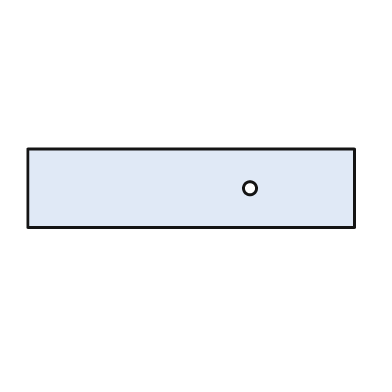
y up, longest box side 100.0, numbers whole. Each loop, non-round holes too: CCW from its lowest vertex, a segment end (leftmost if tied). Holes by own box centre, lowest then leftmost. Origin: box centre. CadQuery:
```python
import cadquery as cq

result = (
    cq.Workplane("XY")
    .moveTo(-50.0, -12.0)
    .lineTo(50.0, -12.0)
    .lineTo(50.0, 12.0)
    .lineTo(-50.0, 12.0)
    .close()
    .moveTo(18.0, 0.0)
    .circle(2.0)
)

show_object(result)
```